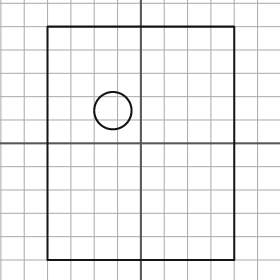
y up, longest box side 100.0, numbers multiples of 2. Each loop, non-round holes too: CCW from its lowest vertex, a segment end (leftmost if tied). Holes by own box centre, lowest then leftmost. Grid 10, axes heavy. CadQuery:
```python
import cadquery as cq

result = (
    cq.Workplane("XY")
    .moveTo(-40.0, -50.0)
    .lineTo(40.0, -50.0)
    .lineTo(40.0, 50.0)
    .lineTo(-40.0, 50.0)
    .close()
    .moveTo(-12.0, 14.0)
    .circle(8.0)
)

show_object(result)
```